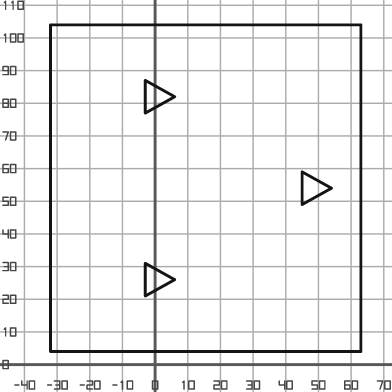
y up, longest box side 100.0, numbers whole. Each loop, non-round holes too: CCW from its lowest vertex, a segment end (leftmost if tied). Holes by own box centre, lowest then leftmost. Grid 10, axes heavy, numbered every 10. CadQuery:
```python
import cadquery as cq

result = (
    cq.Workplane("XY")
    .moveTo(-32.0, 4.0)
    .lineTo(63.0, 4.0)
    .lineTo(63.0, 104.0)
    .lineTo(-32.0, 104.0)
    .close()
    .moveTo(-3.0, 21.0)
    .lineTo(6.0, 26.0)
    .lineTo(-3.0, 31.0)
    .close()
    .moveTo(45.0, 49.0)
    .lineTo(54.0, 54.0)
    .lineTo(45.0, 59.0)
    .close()
    .moveTo(-3.0, 77.0)
    .lineTo(6.0, 82.0)
    .lineTo(-3.0, 87.0)
    .close()
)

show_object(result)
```